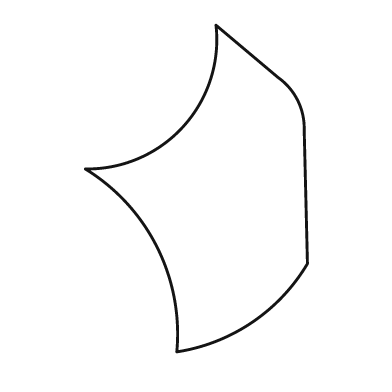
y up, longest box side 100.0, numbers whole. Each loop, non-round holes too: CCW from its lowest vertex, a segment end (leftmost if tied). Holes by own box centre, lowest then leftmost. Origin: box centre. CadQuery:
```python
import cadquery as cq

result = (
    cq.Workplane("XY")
    .moveTo(-6.0, -50.0)
    .threePointArc((17.0, -41.0), (34.0, -23.0))
    .lineTo(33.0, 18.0)
    .threePointArc((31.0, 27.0), (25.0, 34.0))
    .lineTo(6.0, 50.0)
    .threePointArc((-4.0, 19.0), (-34.0, 6.0))
    .threePointArc((-12.0, -18.0), (-6.0, -50.0))
    .close()
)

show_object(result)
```